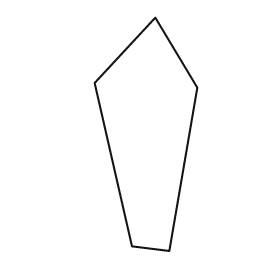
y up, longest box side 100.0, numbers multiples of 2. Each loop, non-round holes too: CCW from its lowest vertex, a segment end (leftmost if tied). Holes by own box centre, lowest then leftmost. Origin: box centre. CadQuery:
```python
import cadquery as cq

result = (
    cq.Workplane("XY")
    .moveTo(10.0, -50.0)
    .lineTo(22.0, 20.0)
    .lineTo(4.0, 50.0)
    .lineTo(-22.0, 22.0)
    .lineTo(-6.0, -48.0)
    .close()
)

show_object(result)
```